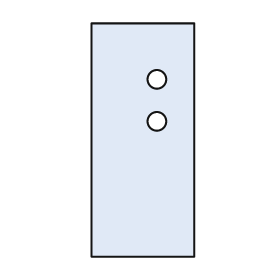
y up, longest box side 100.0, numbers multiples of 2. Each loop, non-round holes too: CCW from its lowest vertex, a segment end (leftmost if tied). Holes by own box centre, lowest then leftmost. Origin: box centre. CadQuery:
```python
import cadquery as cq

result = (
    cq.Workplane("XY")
    .moveTo(-22.0, -50.0)
    .lineTo(22.0, -50.0)
    .lineTo(22.0, 50.0)
    .lineTo(-22.0, 50.0)
    .close()
    .moveTo(6.0, 8.0)
    .circle(4.0)
    .moveTo(6.0, 26.0)
    .circle(4.0)
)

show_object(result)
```